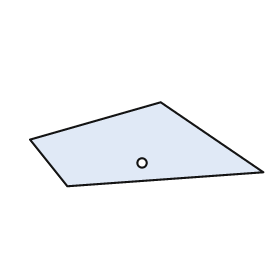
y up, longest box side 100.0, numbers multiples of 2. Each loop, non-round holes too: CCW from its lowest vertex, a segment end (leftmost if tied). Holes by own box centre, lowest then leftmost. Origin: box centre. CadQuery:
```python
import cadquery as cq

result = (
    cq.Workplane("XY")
    .moveTo(-34.0, -18.0)
    .lineTo(50.0, -12.0)
    .lineTo(6.0, 18.0)
    .lineTo(-50.0, 2.0)
    .close()
    .moveTo(-2.0, -8.0)
    .circle(2.0)
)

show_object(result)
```